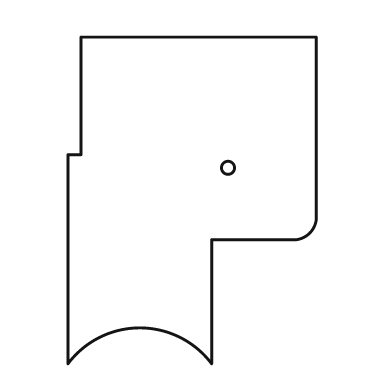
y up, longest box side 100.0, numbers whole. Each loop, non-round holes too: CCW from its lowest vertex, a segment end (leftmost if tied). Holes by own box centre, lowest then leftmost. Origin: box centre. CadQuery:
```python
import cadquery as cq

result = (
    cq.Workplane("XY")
    .moveTo(-38.0, -50.0)
    .threePointArc((-16.0, -39.0), (6.0, -50.0))
    .lineTo(6.0, -12.0)
    .lineTo(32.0, -12.0)
    .threePointArc((36.0, -10.0), (38.0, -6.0))
    .lineTo(38.0, 50.0)
    .lineTo(-34.0, 50.0)
    .lineTo(-34.0, 14.0)
    .lineTo(-38.0, 14.0)
    .close()
    .moveTo(11.0, 10.0)
    .circle(2.0)
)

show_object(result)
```